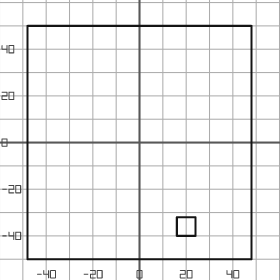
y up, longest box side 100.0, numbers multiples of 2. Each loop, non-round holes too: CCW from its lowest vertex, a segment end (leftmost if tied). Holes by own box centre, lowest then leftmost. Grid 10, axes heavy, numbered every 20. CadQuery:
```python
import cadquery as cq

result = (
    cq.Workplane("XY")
    .moveTo(-48.0, -50.0)
    .lineTo(48.0, -50.0)
    .lineTo(48.0, 50.0)
    .lineTo(-48.0, 50.0)
    .close()
    .moveTo(16.0, -40.0)
    .lineTo(24.0, -40.0)
    .lineTo(24.0, -32.0)
    .lineTo(16.0, -32.0)
    .close()
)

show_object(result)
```